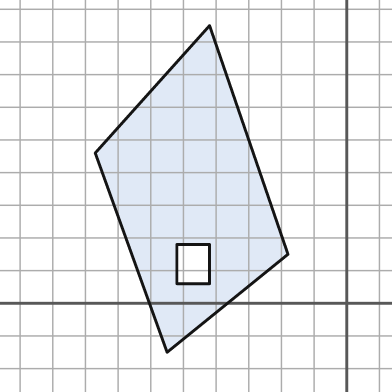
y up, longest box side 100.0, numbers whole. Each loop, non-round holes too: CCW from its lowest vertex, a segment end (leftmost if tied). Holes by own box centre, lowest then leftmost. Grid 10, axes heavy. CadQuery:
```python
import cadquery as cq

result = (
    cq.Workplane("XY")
    .moveTo(-55.0, -15.0)
    .lineTo(-18.0, 15.0)
    .lineTo(-42.0, 85.0)
    .lineTo(-77.0, 46.0)
    .close()
    .moveTo(-52.0, 6.0)
    .lineTo(-42.0, 6.0)
    .lineTo(-42.0, 18.0)
    .lineTo(-52.0, 18.0)
    .close()
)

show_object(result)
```